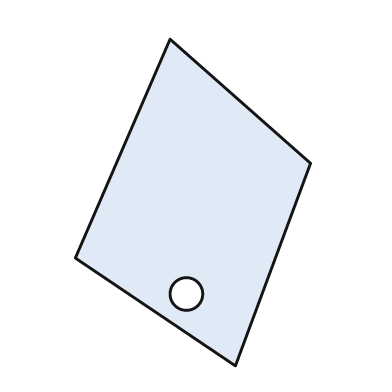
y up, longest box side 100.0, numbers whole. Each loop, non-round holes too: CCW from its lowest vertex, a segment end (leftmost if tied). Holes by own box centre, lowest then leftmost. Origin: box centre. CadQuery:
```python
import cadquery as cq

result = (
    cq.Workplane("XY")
    .moveTo(13.0, -50.0)
    .lineTo(36.0, 12.0)
    .lineTo(-7.0, 50.0)
    .lineTo(-36.0, -17.0)
    .close()
    .moveTo(-2.0, -28.0)
    .circle(5.0)
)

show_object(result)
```